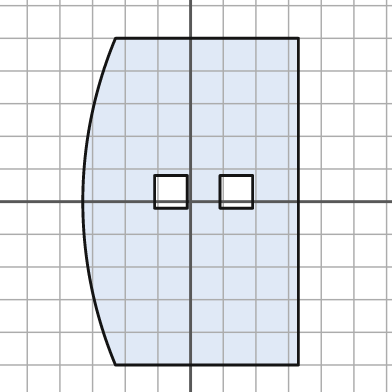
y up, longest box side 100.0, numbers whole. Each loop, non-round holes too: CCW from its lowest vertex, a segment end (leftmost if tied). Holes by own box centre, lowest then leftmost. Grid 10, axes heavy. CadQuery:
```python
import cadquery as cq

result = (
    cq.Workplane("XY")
    .moveTo(-23.0, -50.0)
    .lineTo(33.0, -50.0)
    .lineTo(33.0, 50.0)
    .lineTo(-23.0, 50.0)
    .threePointArc((-33.0, 0.0), (-23.0, -50.0))
    .close()
    .moveTo(-11.0, -2.0)
    .lineTo(-1.0, -2.0)
    .lineTo(-1.0, 8.0)
    .lineTo(-11.0, 8.0)
    .close()
    .moveTo(9.0, -2.0)
    .lineTo(19.0, -2.0)
    .lineTo(19.0, 8.0)
    .lineTo(9.0, 8.0)
    .close()
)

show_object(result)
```